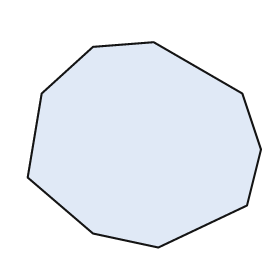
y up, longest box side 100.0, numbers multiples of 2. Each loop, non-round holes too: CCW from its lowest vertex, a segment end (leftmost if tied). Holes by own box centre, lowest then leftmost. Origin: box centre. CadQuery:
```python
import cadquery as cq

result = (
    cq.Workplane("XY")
    .moveTo(6.0, -44.0)
    .lineTo(44.0, -26.0)
    .lineTo(50.0, -2.0)
    .lineTo(42.0, 22.0)
    .lineTo(4.0, 44.0)
    .lineTo(-22.0, 42.0)
    .lineTo(-44.0, 22.0)
    .lineTo(-50.0, -14.0)
    .lineTo(-22.0, -38.0)
    .close()
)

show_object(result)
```